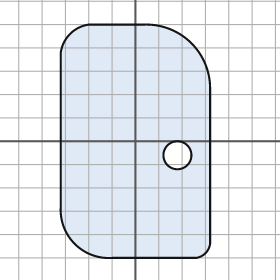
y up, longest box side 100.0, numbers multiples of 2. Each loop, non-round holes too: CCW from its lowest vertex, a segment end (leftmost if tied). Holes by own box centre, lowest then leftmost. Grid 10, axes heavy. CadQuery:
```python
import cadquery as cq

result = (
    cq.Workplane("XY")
    .moveTo(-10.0, -50.0)
    .lineTo(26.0, -50.0)
    .threePointArc((30.0, -48.0), (32.0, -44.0))
    .lineTo(32.0, 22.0)
    .threePointArc((24.0, 42.0), (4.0, 50.0))
    .lineTo(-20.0, 50.0)
    .threePointArc((-28.0, 46.0), (-32.0, 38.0))
    .lineTo(-32.0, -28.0)
    .threePointArc((-26.0, -44.0), (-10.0, -50.0))
    .close()
    .moveTo(18.0, -6.0)
    .circle(6.0)
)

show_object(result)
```